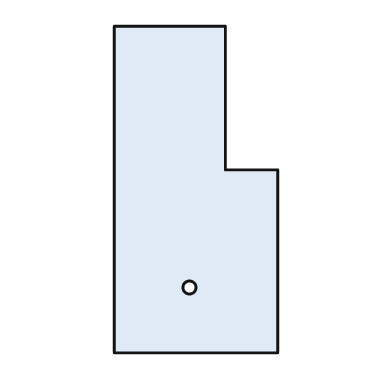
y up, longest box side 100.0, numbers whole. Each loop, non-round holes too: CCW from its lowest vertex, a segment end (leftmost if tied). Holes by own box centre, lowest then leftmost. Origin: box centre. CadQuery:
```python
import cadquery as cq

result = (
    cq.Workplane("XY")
    .moveTo(-25.0, -50.0)
    .lineTo(25.0, -50.0)
    .lineTo(25.0, 6.0)
    .lineTo(9.0, 6.0)
    .lineTo(9.0, 50.0)
    .lineTo(-25.0, 50.0)
    .close()
    .moveTo(-2.0, -30.0)
    .circle(2.0)
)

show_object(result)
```